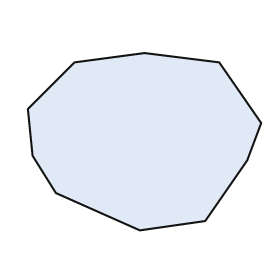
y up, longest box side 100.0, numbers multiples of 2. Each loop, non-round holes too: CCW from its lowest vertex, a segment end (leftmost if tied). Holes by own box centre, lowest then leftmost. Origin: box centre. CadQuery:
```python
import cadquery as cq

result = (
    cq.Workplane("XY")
    .moveTo(-2.0, -38.0)
    .lineTo(26.0, -34.0)
    .lineTo(44.0, -8.0)
    .lineTo(50.0, 8.0)
    .lineTo(32.0, 34.0)
    .lineTo(0.0, 38.0)
    .lineTo(-30.0, 34.0)
    .lineTo(-50.0, 14.0)
    .lineTo(-48.0, -6.0)
    .lineTo(-38.0, -22.0)
    .close()
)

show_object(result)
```